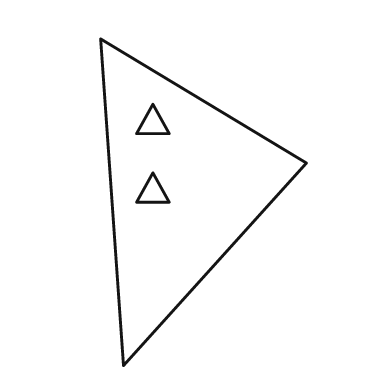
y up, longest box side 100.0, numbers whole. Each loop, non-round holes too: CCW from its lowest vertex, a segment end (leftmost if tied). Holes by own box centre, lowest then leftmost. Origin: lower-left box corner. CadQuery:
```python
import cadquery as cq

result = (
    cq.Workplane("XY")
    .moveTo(7.0, 0.0)
    .lineTo(63.0, 62.0)
    .lineTo(0.0, 100.0)
    .close()
    .moveTo(11.0, 50.0)
    .lineTo(21.0, 50.0)
    .lineTo(16.0, 59.0)
    .close()
    .moveTo(11.0, 71.0)
    .lineTo(21.0, 71.0)
    .lineTo(16.0, 80.0)
    .close()
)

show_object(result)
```